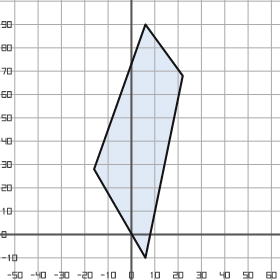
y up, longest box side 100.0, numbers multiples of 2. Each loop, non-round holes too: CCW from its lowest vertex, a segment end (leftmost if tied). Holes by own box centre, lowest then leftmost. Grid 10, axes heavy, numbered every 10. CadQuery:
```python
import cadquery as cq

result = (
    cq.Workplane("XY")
    .moveTo(6.0, -10.0)
    .lineTo(22.0, 68.0)
    .lineTo(6.0, 90.0)
    .lineTo(-16.0, 28.0)
    .close()
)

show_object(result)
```